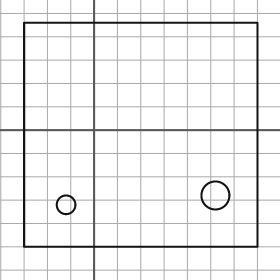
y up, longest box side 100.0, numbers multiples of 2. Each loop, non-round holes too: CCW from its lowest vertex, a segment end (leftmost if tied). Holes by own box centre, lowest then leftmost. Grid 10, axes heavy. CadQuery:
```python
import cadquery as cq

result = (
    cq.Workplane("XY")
    .moveTo(-30.0, -50.0)
    .lineTo(70.0, -50.0)
    .lineTo(70.0, 46.0)
    .lineTo(-30.0, 46.0)
    .close()
    .moveTo(-12.0, -32.0)
    .circle(4.0)
    .moveTo(52.0, -28.0)
    .circle(6.0)
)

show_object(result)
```